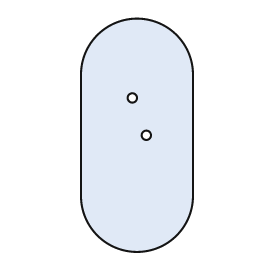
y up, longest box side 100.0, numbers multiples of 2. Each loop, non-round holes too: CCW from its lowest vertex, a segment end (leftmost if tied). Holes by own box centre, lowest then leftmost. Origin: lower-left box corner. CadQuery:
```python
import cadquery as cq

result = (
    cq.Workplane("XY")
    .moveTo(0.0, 24.0)
    .threePointArc((24.0, 0.0), (48.0, 24.0))
    .lineTo(48.0, 76.0)
    .threePointArc((24.0, 100.0), (0.0, 76.0))
    .close()
    .moveTo(28.0, 50.0)
    .circle(2.0)
    .moveTo(22.0, 66.0)
    .circle(2.0)
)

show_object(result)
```